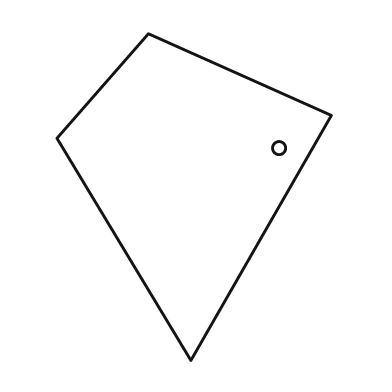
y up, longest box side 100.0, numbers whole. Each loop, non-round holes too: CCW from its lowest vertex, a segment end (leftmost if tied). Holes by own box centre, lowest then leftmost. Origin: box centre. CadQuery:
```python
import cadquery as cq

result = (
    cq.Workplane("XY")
    .moveTo(-1.0, -50.0)
    .lineTo(42.0, 25.0)
    .lineTo(-14.0, 50.0)
    .lineTo(-42.0, 18.0)
    .close()
    .moveTo(26.0, 15.0)
    .circle(2.0)
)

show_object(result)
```